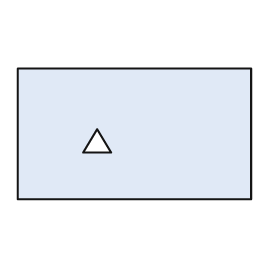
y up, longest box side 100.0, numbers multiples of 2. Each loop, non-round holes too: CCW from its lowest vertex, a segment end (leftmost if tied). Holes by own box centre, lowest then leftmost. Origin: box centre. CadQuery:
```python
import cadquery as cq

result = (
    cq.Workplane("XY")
    .moveTo(-50.0, -28.0)
    .lineTo(50.0, -28.0)
    .lineTo(50.0, 28.0)
    .lineTo(-50.0, 28.0)
    .close()
    .moveTo(-22.0, -8.0)
    .lineTo(-10.0, -8.0)
    .lineTo(-16.0, 2.0)
    .close()
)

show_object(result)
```